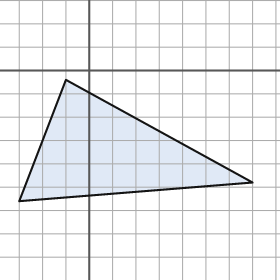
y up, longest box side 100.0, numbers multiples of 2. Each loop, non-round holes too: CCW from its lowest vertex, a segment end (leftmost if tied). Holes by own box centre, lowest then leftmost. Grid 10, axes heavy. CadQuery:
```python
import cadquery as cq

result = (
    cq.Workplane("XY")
    .moveTo(-30.0, -56.0)
    .lineTo(70.0, -48.0)
    .lineTo(-10.0, -4.0)
    .close()
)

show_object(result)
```